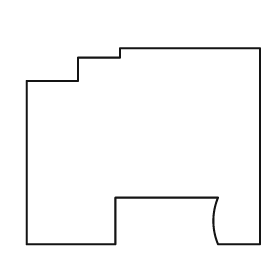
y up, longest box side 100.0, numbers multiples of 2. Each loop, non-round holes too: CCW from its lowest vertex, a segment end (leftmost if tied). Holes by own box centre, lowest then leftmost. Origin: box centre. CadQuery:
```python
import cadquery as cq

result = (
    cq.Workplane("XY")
    .moveTo(-50.0, -42.0)
    .lineTo(-12.0, -42.0)
    .lineTo(-12.0, -22.0)
    .lineTo(32.0, -22.0)
    .threePointArc((30.0, -32.0), (32.0, -42.0))
    .lineTo(50.0, -42.0)
    .lineTo(50.0, 42.0)
    .lineTo(-10.0, 42.0)
    .lineTo(-10.0, 38.0)
    .lineTo(-28.0, 38.0)
    .lineTo(-28.0, 28.0)
    .lineTo(-50.0, 28.0)
    .close()
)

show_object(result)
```